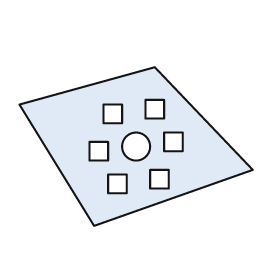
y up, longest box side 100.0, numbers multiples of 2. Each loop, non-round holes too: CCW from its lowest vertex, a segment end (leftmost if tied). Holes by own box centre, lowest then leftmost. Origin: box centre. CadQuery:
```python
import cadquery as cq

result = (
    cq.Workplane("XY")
    .moveTo(-18.0, -34.0)
    .lineTo(50.0, -10.0)
    .lineTo(8.0, 34.0)
    .lineTo(-50.0, 18.0)
    .close()
    .moveTo(-12.0, -20.0)
    .lineTo(-4.0, -20.0)
    .lineTo(-4.0, -12.0)
    .lineTo(-12.0, -12.0)
    .close()
    .moveTo(6.0, -18.0)
    .lineTo(14.0, -18.0)
    .lineTo(14.0, -10.0)
    .lineTo(6.0, -10.0)
    .close()
    .moveTo(-20.0, -6.0)
    .lineTo(-12.0, -6.0)
    .lineTo(-12.0, 2.0)
    .lineTo(-20.0, 2.0)
    .close()
    .moveTo(0.0, 0.0)
    .circle(6.0)
    .moveTo(12.0, -2.0)
    .lineTo(20.0, -2.0)
    .lineTo(20.0, 6.0)
    .lineTo(12.0, 6.0)
    .close()
    .moveTo(-14.0, 10.0)
    .lineTo(-6.0, 10.0)
    .lineTo(-6.0, 18.0)
    .lineTo(-14.0, 18.0)
    .close()
    .moveTo(4.0, 12.0)
    .lineTo(12.0, 12.0)
    .lineTo(12.0, 20.0)
    .lineTo(4.0, 20.0)
    .close()
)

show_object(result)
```